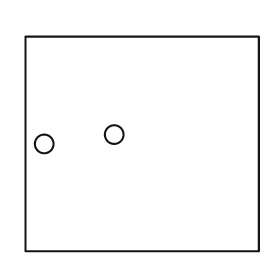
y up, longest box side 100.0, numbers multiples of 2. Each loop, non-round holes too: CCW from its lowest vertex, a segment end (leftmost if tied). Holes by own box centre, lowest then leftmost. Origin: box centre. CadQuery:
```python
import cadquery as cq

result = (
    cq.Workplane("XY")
    .moveTo(-50.0, -46.0)
    .lineTo(50.0, -46.0)
    .lineTo(50.0, 46.0)
    .lineTo(-50.0, 46.0)
    .close()
    .moveTo(-42.0, 0.0)
    .circle(4.0)
    .moveTo(-12.0, 4.0)
    .circle(4.0)
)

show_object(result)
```